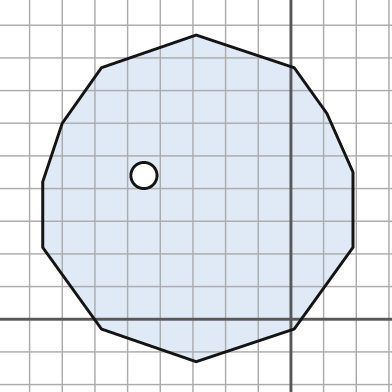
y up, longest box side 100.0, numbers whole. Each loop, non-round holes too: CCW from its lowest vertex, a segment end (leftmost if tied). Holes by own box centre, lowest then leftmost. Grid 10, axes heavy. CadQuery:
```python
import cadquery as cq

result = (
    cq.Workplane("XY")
    .moveTo(-29.0, -13.0)
    .lineTo(1.0, -3.0)
    .lineTo(19.0, 22.0)
    .lineTo(19.0, 45.0)
    .lineTo(11.0, 63.0)
    .lineTo(1.0, 77.0)
    .lineTo(-29.0, 87.0)
    .lineTo(-58.0, 77.0)
    .lineTo(-70.0, 60.0)
    .lineTo(-76.0, 42.0)
    .lineTo(-76.0, 22.0)
    .lineTo(-58.0, -3.0)
    .close()
    .moveTo(-45.0, 44.0)
    .circle(4.0)
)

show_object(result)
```